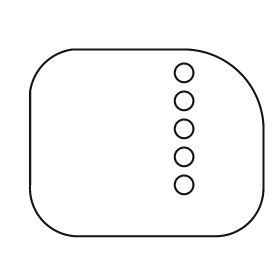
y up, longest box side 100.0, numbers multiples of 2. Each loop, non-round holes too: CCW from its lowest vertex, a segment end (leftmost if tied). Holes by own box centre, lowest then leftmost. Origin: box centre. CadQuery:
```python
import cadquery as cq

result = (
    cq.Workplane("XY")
    .moveTo(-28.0, -40.0)
    .lineTo(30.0, -40.0)
    .threePointArc((44.0, -34.0), (50.0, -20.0))
    .lineTo(50.0, 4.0)
    .threePointArc((40.0, 30.0), (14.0, 40.0))
    .lineTo(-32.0, 40.0)
    .threePointArc((-44.0, 34.0), (-50.0, 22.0))
    .lineTo(-50.0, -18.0)
    .threePointArc((-44.0, -34.0), (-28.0, -40.0))
    .close()
    .moveTo(16.0, -18.0)
    .circle(4.0)
    .moveTo(16.0, -6.0)
    .circle(4.0)
    .moveTo(16.0, 6.0)
    .circle(4.0)
    .moveTo(16.0, 18.0)
    .circle(4.0)
    .moveTo(16.0, 30.0)
    .circle(4.0)
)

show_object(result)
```